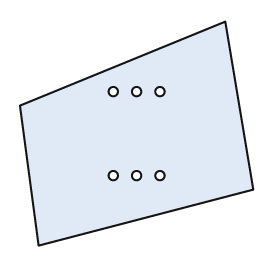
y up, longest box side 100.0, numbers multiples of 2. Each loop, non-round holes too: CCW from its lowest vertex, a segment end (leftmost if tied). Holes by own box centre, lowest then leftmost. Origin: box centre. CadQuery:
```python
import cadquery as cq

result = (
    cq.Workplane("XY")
    .moveTo(-42.0, -48.0)
    .lineTo(50.0, -24.0)
    .lineTo(38.0, 48.0)
    .lineTo(-50.0, 12.0)
    .close()
    .moveTo(-10.0, -18.0)
    .circle(2.0)
    .moveTo(0.0, -18.0)
    .circle(2.0)
    .moveTo(10.0, -18.0)
    .circle(2.0)
    .moveTo(-10.0, 18.0)
    .circle(2.0)
    .moveTo(0.0, 18.0)
    .circle(2.0)
    .moveTo(10.0, 18.0)
    .circle(2.0)
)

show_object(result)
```